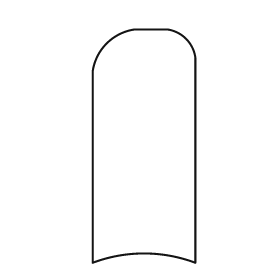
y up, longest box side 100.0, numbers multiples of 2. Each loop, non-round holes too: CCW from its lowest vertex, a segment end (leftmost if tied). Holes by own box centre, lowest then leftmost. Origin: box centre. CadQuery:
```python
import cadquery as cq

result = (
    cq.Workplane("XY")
    .moveTo(-22.0, -50.0)
    .threePointArc((0.0, -46.0), (22.0, -50.0))
    .lineTo(22.0, 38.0)
    .threePointArc((18.0, 46.0), (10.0, 50.0))
    .lineTo(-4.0, 50.0)
    .threePointArc((-16.0, 44.0), (-22.0, 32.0))
    .close()
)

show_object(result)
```